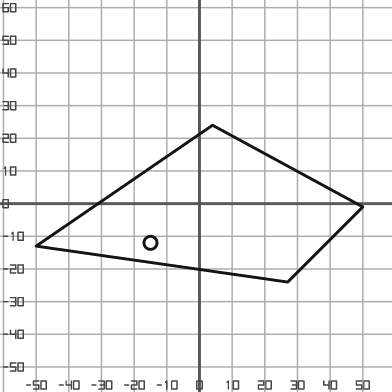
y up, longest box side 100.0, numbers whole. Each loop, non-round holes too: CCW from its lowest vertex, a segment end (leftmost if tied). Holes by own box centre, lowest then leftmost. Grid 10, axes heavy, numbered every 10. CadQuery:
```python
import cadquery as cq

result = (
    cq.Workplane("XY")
    .moveTo(27.0, -24.0)
    .lineTo(50.0, -1.0)
    .lineTo(4.0, 24.0)
    .lineTo(-50.0, -13.0)
    .close()
    .moveTo(-15.0, -12.0)
    .circle(2.0)
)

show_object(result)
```